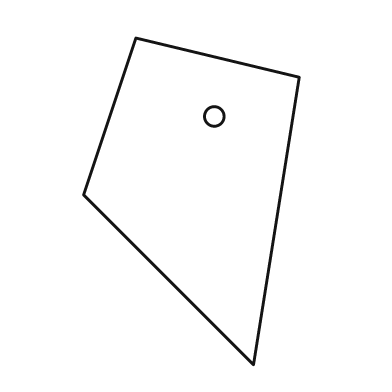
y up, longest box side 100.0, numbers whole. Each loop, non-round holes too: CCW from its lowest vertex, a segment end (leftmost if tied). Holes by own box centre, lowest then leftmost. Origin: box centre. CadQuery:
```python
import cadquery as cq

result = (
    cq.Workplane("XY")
    .moveTo(19.0, -50.0)
    .lineTo(33.0, 38.0)
    .lineTo(-17.0, 50.0)
    .lineTo(-33.0, 2.0)
    .close()
    .moveTo(7.0, 26.0)
    .circle(3.0)
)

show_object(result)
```